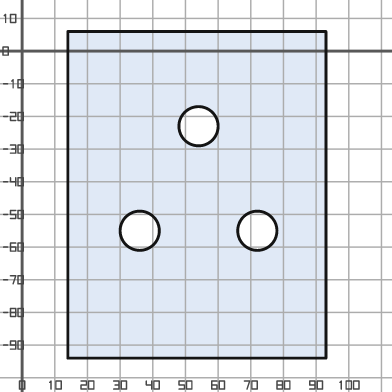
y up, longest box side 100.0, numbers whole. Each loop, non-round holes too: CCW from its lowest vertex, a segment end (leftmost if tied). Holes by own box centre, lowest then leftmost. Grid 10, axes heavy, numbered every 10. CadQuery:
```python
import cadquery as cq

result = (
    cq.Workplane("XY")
    .moveTo(14.0, -94.0)
    .lineTo(93.0, -94.0)
    .lineTo(93.0, 6.0)
    .lineTo(14.0, 6.0)
    .close()
    .moveTo(36.0, -55.0)
    .circle(6.0)
    .moveTo(72.0, -55.0)
    .circle(6.0)
    .moveTo(54.0, -23.0)
    .circle(6.0)
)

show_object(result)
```